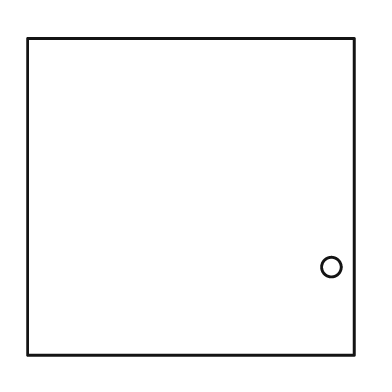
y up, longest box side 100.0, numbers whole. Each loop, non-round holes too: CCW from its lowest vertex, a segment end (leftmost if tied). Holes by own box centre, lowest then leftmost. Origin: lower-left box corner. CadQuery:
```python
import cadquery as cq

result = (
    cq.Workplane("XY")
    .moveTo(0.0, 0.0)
    .lineTo(100.0, 0.0)
    .lineTo(100.0, 97.0)
    .lineTo(0.0, 97.0)
    .close()
    .moveTo(93.0, 27.0)
    .circle(3.0)
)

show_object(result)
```